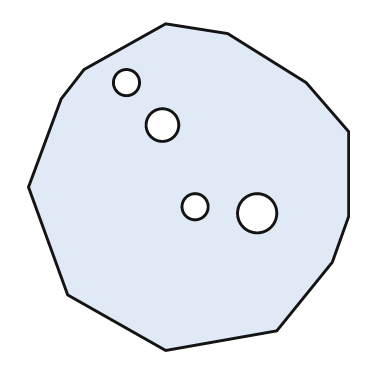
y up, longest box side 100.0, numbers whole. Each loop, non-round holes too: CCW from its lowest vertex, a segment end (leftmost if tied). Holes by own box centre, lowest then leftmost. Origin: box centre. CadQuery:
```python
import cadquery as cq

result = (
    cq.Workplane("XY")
    .moveTo(-7.0, -50.0)
    .lineTo(27.0, -44.0)
    .lineTo(44.0, -23.0)
    .lineTo(49.0, -9.0)
    .lineTo(49.0, 17.0)
    .lineTo(36.0, 32.0)
    .lineTo(12.0, 47.0)
    .lineTo(-7.0, 50.0)
    .lineTo(-32.0, 36.0)
    .lineTo(-39.0, 27.0)
    .lineTo(-49.0, 0.0)
    .lineTo(-37.0, -33.0)
    .close()
    .moveTo(21.0, -8.0)
    .circle(6.0)
    .moveTo(2.0, -6.0)
    .circle(4.0)
    .moveTo(-8.0, 19.0)
    .circle(5.0)
    .moveTo(-19.0, 32.0)
    .circle(4.0)
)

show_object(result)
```